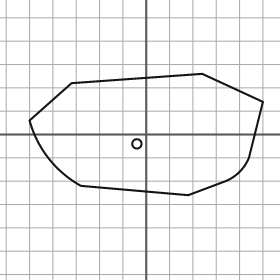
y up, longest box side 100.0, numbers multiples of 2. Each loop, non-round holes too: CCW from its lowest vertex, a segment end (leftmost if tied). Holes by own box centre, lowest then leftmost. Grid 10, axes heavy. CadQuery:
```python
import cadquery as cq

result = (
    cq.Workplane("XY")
    .moveTo(18.0, -26.0)
    .lineTo(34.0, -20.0)
    .threePointArc((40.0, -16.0), (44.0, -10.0))
    .lineTo(50.0, 14.0)
    .lineTo(24.0, 26.0)
    .lineTo(-32.0, 22.0)
    .lineTo(-50.0, 6.0)
    .threePointArc((-42.0, -10.0), (-28.0, -22.0))
    .close()
    .moveTo(-4.0, -4.0)
    .circle(2.0)
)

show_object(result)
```